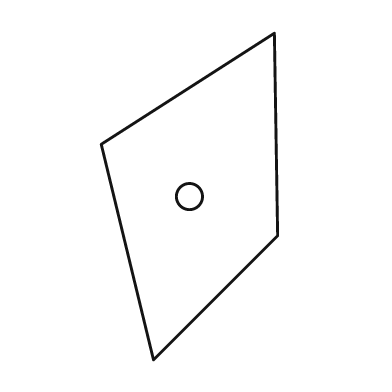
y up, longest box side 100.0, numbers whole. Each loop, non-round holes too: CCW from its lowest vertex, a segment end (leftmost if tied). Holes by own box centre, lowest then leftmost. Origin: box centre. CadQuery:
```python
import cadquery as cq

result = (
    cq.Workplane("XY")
    .moveTo(-11.0, -50.0)
    .lineTo(27.0, -12.0)
    .lineTo(26.0, 50.0)
    .lineTo(-27.0, 16.0)
    .close()
    .moveTo(0.0, 0.0)
    .circle(4.0)
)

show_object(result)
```